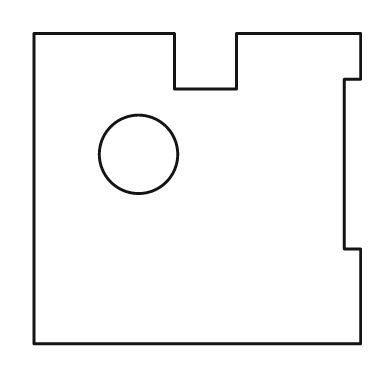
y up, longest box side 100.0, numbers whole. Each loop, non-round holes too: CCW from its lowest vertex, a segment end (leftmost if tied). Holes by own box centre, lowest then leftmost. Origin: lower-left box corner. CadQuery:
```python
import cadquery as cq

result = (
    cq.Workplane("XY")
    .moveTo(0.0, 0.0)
    .lineTo(100.0, 0.0)
    .lineTo(100.0, 29.0)
    .lineTo(95.0, 29.0)
    .lineTo(95.0, 81.0)
    .lineTo(100.0, 81.0)
    .lineTo(100.0, 95.0)
    .lineTo(62.0, 95.0)
    .lineTo(62.0, 78.0)
    .lineTo(43.0, 78.0)
    .lineTo(43.0, 95.0)
    .lineTo(0.0, 95.0)
    .close()
    .moveTo(32.0, 58.0)
    .circle(12.0)
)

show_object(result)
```